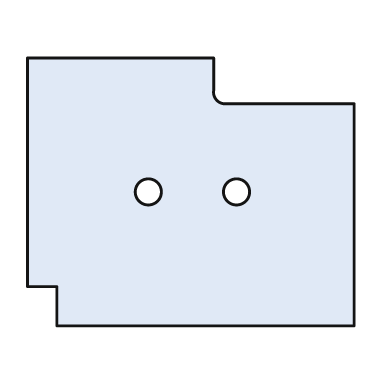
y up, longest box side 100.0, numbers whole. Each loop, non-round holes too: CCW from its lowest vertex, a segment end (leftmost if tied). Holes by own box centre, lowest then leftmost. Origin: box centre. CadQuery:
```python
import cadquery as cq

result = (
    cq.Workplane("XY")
    .moveTo(-41.0, -41.0)
    .lineTo(50.0, -41.0)
    .lineTo(50.0, 27.0)
    .lineTo(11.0, 27.0)
    .threePointArc((8.0, 28.0), (7.0, 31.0))
    .lineTo(7.0, 41.0)
    .lineTo(-50.0, 41.0)
    .lineTo(-50.0, -29.0)
    .lineTo(-41.0, -29.0)
    .close()
    .moveTo(-13.0, 0.0)
    .circle(4.0)
    .moveTo(14.0, 0.0)
    .circle(4.0)
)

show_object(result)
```